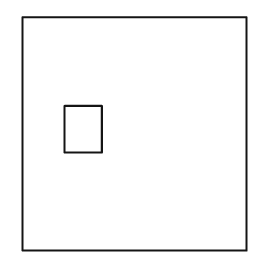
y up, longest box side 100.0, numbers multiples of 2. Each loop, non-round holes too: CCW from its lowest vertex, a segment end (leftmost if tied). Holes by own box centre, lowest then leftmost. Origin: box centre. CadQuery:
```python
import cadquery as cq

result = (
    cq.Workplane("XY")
    .moveTo(-48.0, -50.0)
    .lineTo(48.0, -50.0)
    .lineTo(48.0, 50.0)
    .lineTo(-48.0, 50.0)
    .close()
    .moveTo(-30.0, -8.0)
    .lineTo(-14.0, -8.0)
    .lineTo(-14.0, 12.0)
    .lineTo(-30.0, 12.0)
    .close()
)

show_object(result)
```